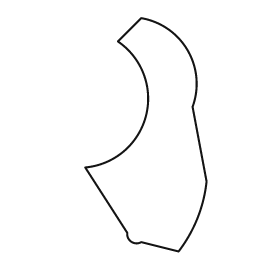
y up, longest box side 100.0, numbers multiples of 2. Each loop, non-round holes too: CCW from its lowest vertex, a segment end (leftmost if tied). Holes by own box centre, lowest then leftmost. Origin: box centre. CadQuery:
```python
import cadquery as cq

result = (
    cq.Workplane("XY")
    .moveTo(14.0, -50.0)
    .threePointArc((22.0, -36.0), (26.0, -20.0))
    .lineTo(20.0, 12.0)
    .threePointArc((18.0, 36.0), (-2.0, 50.0))
    .lineTo(-12.0, 40.0)
    .threePointArc((0.0, 8.0), (-26.0, -14.0))
    .lineTo(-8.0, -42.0)
    .threePointArc((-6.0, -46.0), (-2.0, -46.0))
    .close()
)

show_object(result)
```